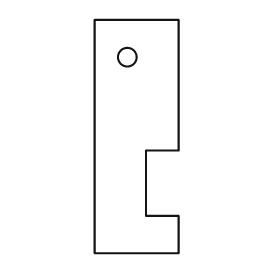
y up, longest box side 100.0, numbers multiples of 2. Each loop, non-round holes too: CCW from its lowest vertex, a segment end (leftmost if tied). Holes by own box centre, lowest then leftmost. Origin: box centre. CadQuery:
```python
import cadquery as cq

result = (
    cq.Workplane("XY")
    .moveTo(-18.0, -50.0)
    .lineTo(18.0, -50.0)
    .lineTo(18.0, -34.0)
    .lineTo(4.0, -34.0)
    .lineTo(4.0, -6.0)
    .lineTo(18.0, -6.0)
    .lineTo(18.0, 50.0)
    .lineTo(-18.0, 50.0)
    .close()
    .moveTo(-4.0, 34.0)
    .circle(4.0)
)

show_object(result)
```